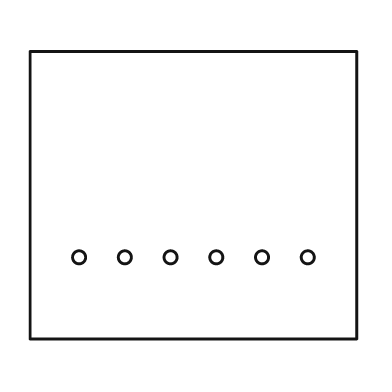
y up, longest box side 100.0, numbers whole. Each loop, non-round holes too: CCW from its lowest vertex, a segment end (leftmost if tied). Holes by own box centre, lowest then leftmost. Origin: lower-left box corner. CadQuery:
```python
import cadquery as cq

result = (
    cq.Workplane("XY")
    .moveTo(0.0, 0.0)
    .lineTo(100.0, 0.0)
    .lineTo(100.0, 88.0)
    .lineTo(0.0, 88.0)
    .close()
    .moveTo(15.0, 25.0)
    .circle(2.0)
    .moveTo(29.0, 25.0)
    .circle(2.0)
    .moveTo(43.0, 25.0)
    .circle(2.0)
    .moveTo(57.0, 25.0)
    .circle(2.0)
    .moveTo(71.0, 25.0)
    .circle(2.0)
    .moveTo(85.0, 25.0)
    .circle(2.0)
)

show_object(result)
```